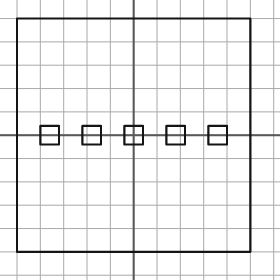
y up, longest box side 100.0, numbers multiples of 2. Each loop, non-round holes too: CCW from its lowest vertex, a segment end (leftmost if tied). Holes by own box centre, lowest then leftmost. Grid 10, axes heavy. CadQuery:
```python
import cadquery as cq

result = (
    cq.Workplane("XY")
    .moveTo(-50.0, -50.0)
    .lineTo(50.0, -50.0)
    .lineTo(50.0, 50.0)
    .lineTo(-50.0, 50.0)
    .close()
    .moveTo(-40.0, -4.0)
    .lineTo(-32.0, -4.0)
    .lineTo(-32.0, 4.0)
    .lineTo(-40.0, 4.0)
    .close()
    .moveTo(-22.0, -4.0)
    .lineTo(-14.0, -4.0)
    .lineTo(-14.0, 4.0)
    .lineTo(-22.0, 4.0)
    .close()
    .moveTo(-4.0, -4.0)
    .lineTo(4.0, -4.0)
    .lineTo(4.0, 4.0)
    .lineTo(-4.0, 4.0)
    .close()
    .moveTo(14.0, -4.0)
    .lineTo(22.0, -4.0)
    .lineTo(22.0, 4.0)
    .lineTo(14.0, 4.0)
    .close()
    .moveTo(32.0, -4.0)
    .lineTo(40.0, -4.0)
    .lineTo(40.0, 4.0)
    .lineTo(32.0, 4.0)
    .close()
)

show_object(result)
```